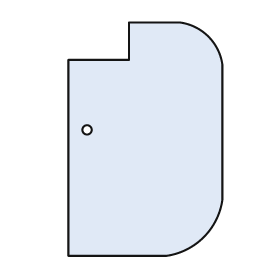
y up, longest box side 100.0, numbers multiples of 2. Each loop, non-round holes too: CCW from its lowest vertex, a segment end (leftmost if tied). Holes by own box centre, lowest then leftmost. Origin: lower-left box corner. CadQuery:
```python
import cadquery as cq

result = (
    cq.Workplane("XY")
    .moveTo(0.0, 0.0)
    .lineTo(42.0, 0.0)
    .threePointArc((58.0, 8.0), (66.0, 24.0))
    .lineTo(66.0, 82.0)
    .threePointArc((60.0, 94.0), (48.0, 100.0))
    .lineTo(26.0, 100.0)
    .lineTo(26.0, 84.0)
    .lineTo(0.0, 84.0)
    .close()
    .moveTo(8.0, 54.0)
    .circle(2.0)
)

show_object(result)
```